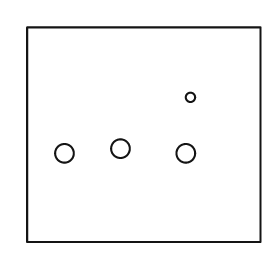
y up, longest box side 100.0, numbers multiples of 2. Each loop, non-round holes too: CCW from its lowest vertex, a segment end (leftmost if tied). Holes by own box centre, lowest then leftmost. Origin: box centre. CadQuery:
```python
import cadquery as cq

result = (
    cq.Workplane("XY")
    .moveTo(-50.0, -46.0)
    .lineTo(50.0, -46.0)
    .lineTo(50.0, 46.0)
    .lineTo(-50.0, 46.0)
    .close()
    .moveTo(-34.0, -8.0)
    .circle(4.0)
    .moveTo(18.0, -8.0)
    .circle(4.0)
    .moveTo(-10.0, -6.0)
    .circle(4.0)
    .moveTo(20.0, 16.0)
    .circle(2.0)
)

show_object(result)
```